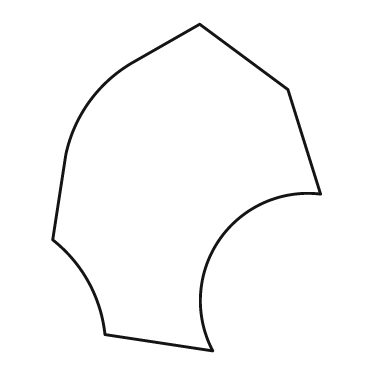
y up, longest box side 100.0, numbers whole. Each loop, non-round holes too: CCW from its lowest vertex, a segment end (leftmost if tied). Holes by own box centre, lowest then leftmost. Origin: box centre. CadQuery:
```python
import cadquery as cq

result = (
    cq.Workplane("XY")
    .moveTo(8.0, -50.0)
    .threePointArc((10.0, -16.0), (41.0, -2.0))
    .lineTo(31.0, 30.0)
    .lineTo(4.0, 50.0)
    .lineTo(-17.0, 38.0)
    .threePointArc((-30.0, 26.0), (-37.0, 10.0))
    .lineTo(-41.0, -16.0)
    .threePointArc((-30.0, -29.0), (-25.0, -45.0))
    .close()
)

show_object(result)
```